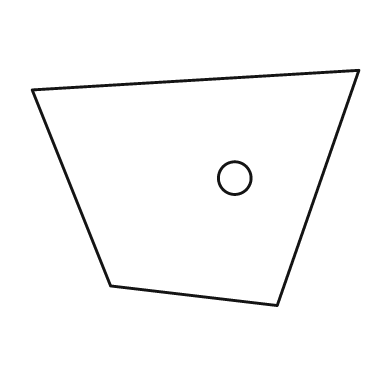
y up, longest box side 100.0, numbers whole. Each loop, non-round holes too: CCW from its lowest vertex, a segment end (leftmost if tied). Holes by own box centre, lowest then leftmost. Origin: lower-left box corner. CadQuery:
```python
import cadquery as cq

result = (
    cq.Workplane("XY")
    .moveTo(75.0, 0.0)
    .lineTo(100.0, 72.0)
    .lineTo(0.0, 66.0)
    .lineTo(24.0, 6.0)
    .close()
    .moveTo(62.0, 39.0)
    .circle(5.0)
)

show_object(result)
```